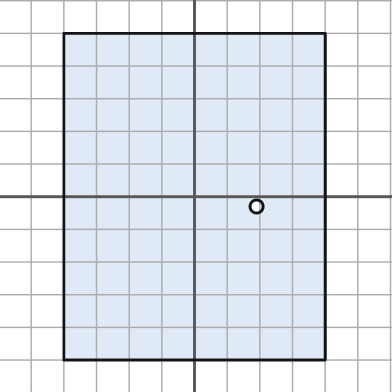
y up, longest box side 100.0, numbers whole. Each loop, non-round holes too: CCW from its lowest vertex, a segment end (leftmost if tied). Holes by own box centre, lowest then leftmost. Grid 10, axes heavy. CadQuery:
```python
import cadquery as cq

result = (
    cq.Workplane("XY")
    .moveTo(-40.0, -50.0)
    .lineTo(40.0, -50.0)
    .lineTo(40.0, 50.0)
    .lineTo(-40.0, 50.0)
    .close()
    .moveTo(19.0, -3.0)
    .circle(2.0)
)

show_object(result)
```